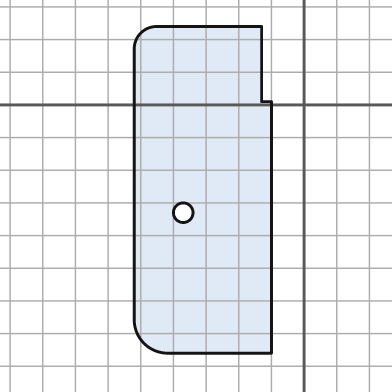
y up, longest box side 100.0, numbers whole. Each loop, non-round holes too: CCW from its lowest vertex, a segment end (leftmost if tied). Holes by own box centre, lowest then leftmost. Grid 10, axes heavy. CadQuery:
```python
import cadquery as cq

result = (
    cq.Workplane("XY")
    .moveTo(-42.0, -76.0)
    .lineTo(-10.0, -76.0)
    .lineTo(-10.0, 1.0)
    .lineTo(-13.0, 1.0)
    .lineTo(-13.0, 24.0)
    .lineTo(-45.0, 24.0)
    .threePointArc((-50.0, 22.0), (-52.0, 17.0))
    .lineTo(-52.0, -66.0)
    .threePointArc((-49.0, -73.0), (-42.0, -76.0))
    .close()
    .moveTo(-37.0, -33.0)
    .circle(3.0)
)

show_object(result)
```